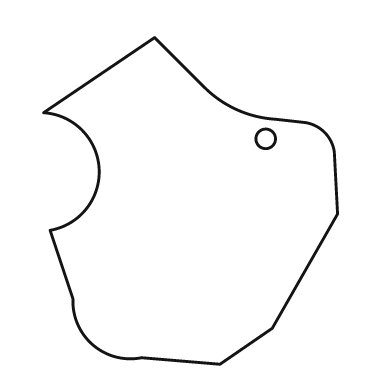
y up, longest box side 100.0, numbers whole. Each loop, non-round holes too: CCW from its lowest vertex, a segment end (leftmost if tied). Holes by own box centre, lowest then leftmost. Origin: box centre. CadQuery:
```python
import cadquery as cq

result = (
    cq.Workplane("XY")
    .moveTo(9.0, -50.0)
    .lineTo(25.0, -39.0)
    .lineTo(45.0, -4.0)
    .lineTo(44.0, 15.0)
    .threePointArc((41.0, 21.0), (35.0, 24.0))
    .lineTo(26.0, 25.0)
    .threePointArc((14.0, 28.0), (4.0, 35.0))
    .lineTo(-11.0, 50.0)
    .lineTo(-45.0, 27.0)
    .threePointArc((-28.0, 10.0), (-43.0, -9.0))
    .lineTo(-36.0, -30.0)
    .threePointArc((-30.0, -44.0), (-15.0, -48.0))
    .close()
    .moveTo(23.0, 19.0)
    .circle(3.0)
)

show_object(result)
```